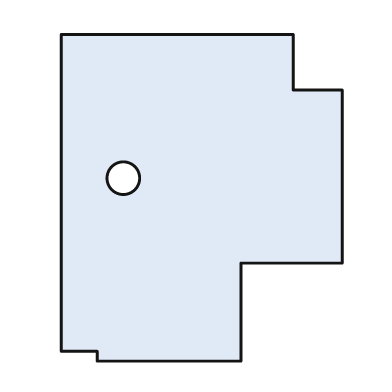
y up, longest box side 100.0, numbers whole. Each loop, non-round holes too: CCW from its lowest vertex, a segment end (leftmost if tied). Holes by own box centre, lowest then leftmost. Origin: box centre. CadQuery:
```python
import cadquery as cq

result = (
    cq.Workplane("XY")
    .moveTo(-32.0, -50.0)
    .lineTo(12.0, -50.0)
    .lineTo(12.0, -20.0)
    .lineTo(43.0, -20.0)
    .lineTo(43.0, 33.0)
    .lineTo(28.0, 33.0)
    .lineTo(28.0, 50.0)
    .lineTo(-43.0, 50.0)
    .lineTo(-43.0, -47.0)
    .lineTo(-32.0, -47.0)
    .close()
    .moveTo(-24.0, 6.0)
    .circle(5.0)
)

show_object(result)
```